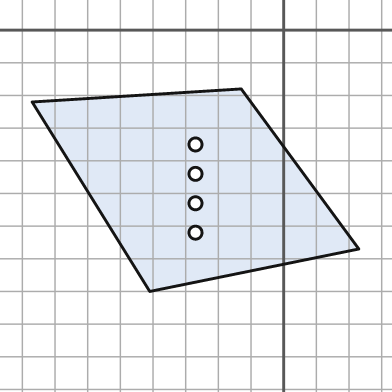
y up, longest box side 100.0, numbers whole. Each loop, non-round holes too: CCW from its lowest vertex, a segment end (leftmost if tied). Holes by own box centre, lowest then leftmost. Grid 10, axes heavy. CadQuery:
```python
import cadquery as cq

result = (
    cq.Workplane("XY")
    .moveTo(-41.0, -80.0)
    .lineTo(23.0, -67.0)
    .lineTo(-13.0, -18.0)
    .lineTo(-77.0, -22.0)
    .close()
    .moveTo(-27.0, -62.0)
    .circle(2.0)
    .moveTo(-27.0, -53.0)
    .circle(2.0)
    .moveTo(-27.0, -44.0)
    .circle(2.0)
    .moveTo(-27.0, -35.0)
    .circle(2.0)
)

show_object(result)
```